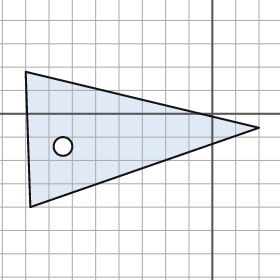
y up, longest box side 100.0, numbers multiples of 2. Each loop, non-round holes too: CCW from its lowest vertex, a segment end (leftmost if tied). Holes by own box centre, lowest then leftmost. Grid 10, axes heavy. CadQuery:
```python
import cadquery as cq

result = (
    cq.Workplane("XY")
    .moveTo(-78.0, -40.0)
    .lineTo(20.0, -6.0)
    .lineTo(-80.0, 18.0)
    .close()
    .moveTo(-64.0, -14.0)
    .circle(4.0)
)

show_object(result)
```